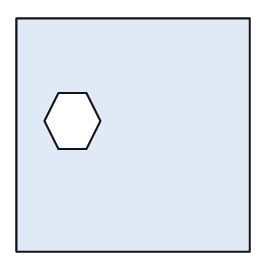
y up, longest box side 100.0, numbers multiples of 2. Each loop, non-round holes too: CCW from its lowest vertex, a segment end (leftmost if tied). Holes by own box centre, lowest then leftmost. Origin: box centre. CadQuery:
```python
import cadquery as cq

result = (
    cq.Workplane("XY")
    .moveTo(-50.0, -50.0)
    .lineTo(50.0, -50.0)
    .lineTo(50.0, 50.0)
    .lineTo(-50.0, 50.0)
    .close()
    .moveTo(-32.0, -6.0)
    .lineTo(-20.0, -6.0)
    .lineTo(-14.0, 6.0)
    .lineTo(-20.0, 18.0)
    .lineTo(-32.0, 18.0)
    .lineTo(-38.0, 6.0)
    .close()
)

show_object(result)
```